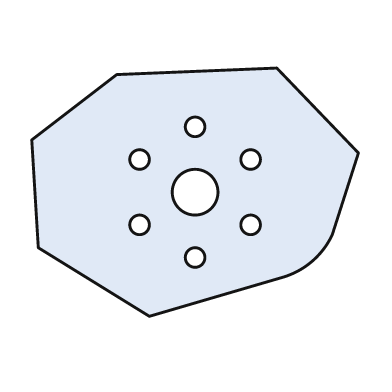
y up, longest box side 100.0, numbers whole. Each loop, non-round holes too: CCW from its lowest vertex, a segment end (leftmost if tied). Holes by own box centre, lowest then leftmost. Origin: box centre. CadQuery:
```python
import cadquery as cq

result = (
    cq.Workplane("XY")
    .moveTo(-14.0, -38.0)
    .lineTo(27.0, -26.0)
    .threePointArc((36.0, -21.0), (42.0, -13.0))
    .lineTo(50.0, 12.0)
    .lineTo(25.0, 38.0)
    .lineTo(-24.0, 36.0)
    .lineTo(-50.0, 16.0)
    .lineTo(-48.0, -17.0)
    .close()
    .moveTo(0.0, -20.0)
    .circle(3.0)
    .moveTo(-17.0, -10.0)
    .circle(3.0)
    .moveTo(17.0, -10.0)
    .circle(3.0)
    .moveTo(0.0, 0.0)
    .circle(7.0)
    .moveTo(-17.0, 10.0)
    .circle(3.0)
    .moveTo(17.0, 10.0)
    .circle(3.0)
    .moveTo(0.0, 20.0)
    .circle(3.0)
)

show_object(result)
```